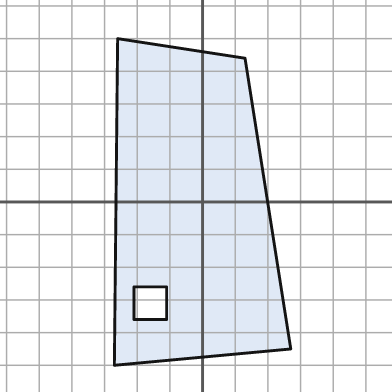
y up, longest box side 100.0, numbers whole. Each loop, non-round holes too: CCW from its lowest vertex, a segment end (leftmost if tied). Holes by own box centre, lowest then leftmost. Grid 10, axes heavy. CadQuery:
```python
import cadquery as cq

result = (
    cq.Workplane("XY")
    .moveTo(-27.0, -50.0)
    .lineTo(27.0, -45.0)
    .lineTo(13.0, 44.0)
    .lineTo(-26.0, 50.0)
    .close()
    .moveTo(-21.0, -36.0)
    .lineTo(-11.0, -36.0)
    .lineTo(-11.0, -26.0)
    .lineTo(-21.0, -26.0)
    .close()
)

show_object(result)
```